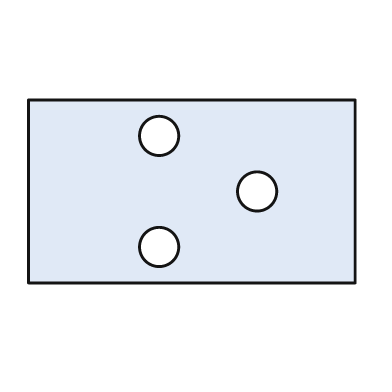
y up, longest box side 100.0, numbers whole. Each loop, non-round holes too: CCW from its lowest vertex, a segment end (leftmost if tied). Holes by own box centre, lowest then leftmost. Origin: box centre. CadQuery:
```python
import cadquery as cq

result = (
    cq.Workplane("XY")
    .moveTo(-50.0, -28.0)
    .lineTo(50.0, -28.0)
    .lineTo(50.0, 28.0)
    .lineTo(-50.0, 28.0)
    .close()
    .moveTo(-10.0, -17.0)
    .circle(6.0)
    .moveTo(20.0, 0.0)
    .circle(6.0)
    .moveTo(-10.0, 17.0)
    .circle(6.0)
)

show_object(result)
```